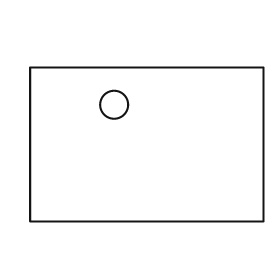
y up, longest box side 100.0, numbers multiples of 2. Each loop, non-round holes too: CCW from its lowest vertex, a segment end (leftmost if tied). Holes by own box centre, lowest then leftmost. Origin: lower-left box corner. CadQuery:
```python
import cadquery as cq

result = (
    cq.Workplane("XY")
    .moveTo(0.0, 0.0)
    .lineTo(100.0, 0.0)
    .lineTo(100.0, 66.0)
    .lineTo(0.0, 66.0)
    .close()
    .moveTo(36.0, 50.0)
    .circle(6.0)
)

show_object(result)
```